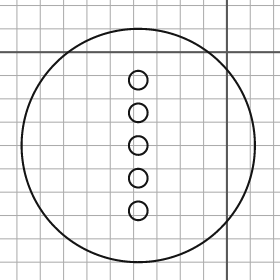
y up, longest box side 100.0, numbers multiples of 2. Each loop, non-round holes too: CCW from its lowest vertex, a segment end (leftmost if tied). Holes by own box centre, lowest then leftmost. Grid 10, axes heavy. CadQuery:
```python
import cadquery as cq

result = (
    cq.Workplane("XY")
    .moveTo(-38.0, -40.0)
    .circle(50.0)
    .moveTo(-38.0, -68.0)
    .circle(4.0)
    .moveTo(-38.0, -54.0)
    .circle(4.0)
    .moveTo(-38.0, -40.0)
    .circle(4.0)
    .moveTo(-38.0, -26.0)
    .circle(4.0)
    .moveTo(-38.0, -12.0)
    .circle(4.0)
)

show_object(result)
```